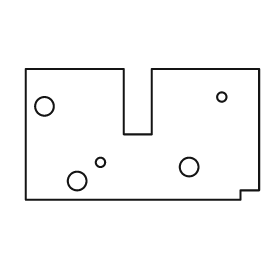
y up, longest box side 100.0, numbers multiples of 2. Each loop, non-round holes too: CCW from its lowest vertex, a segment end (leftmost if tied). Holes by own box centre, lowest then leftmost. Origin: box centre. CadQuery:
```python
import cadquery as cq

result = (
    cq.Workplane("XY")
    .moveTo(-50.0, -28.0)
    .lineTo(42.0, -28.0)
    .lineTo(42.0, -24.0)
    .lineTo(50.0, -24.0)
    .lineTo(50.0, 28.0)
    .lineTo(4.0, 28.0)
    .lineTo(4.0, 0.0)
    .lineTo(-8.0, 0.0)
    .lineTo(-8.0, 28.0)
    .lineTo(-50.0, 28.0)
    .close()
    .moveTo(-28.0, -20.0)
    .circle(4.0)
    .moveTo(20.0, -14.0)
    .circle(4.0)
    .moveTo(-18.0, -12.0)
    .circle(2.0)
    .moveTo(-42.0, 12.0)
    .circle(4.0)
    .moveTo(34.0, 16.0)
    .circle(2.0)
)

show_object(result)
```